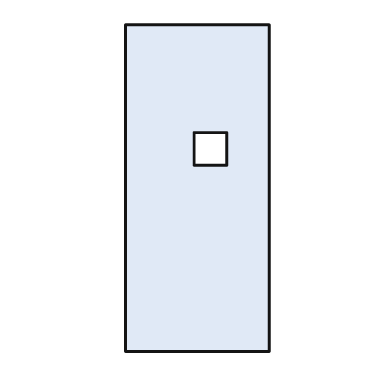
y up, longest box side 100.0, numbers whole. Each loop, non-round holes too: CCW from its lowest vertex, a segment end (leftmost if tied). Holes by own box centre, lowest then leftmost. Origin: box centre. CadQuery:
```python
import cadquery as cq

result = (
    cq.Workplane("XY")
    .moveTo(-22.0, -50.0)
    .lineTo(22.0, -50.0)
    .lineTo(22.0, 50.0)
    .lineTo(-22.0, 50.0)
    .close()
    .moveTo(-1.0, 7.0)
    .lineTo(9.0, 7.0)
    .lineTo(9.0, 17.0)
    .lineTo(-1.0, 17.0)
    .close()
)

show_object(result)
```